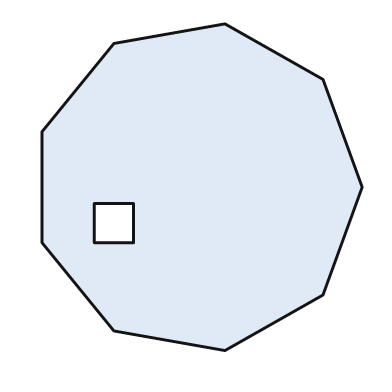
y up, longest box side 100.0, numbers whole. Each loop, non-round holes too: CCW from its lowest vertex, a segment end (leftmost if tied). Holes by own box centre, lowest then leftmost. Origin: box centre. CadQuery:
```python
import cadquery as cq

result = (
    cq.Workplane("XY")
    .moveTo(7.0, -50.0)
    .lineTo(37.0, -33.0)
    .lineTo(49.0, 0.0)
    .lineTo(37.0, 33.0)
    .lineTo(7.0, 50.0)
    .lineTo(-27.0, 44.0)
    .lineTo(-49.0, 17.0)
    .lineTo(-49.0, -17.0)
    .lineTo(-27.0, -44.0)
    .close()
    .moveTo(-33.0, -17.0)
    .lineTo(-21.0, -17.0)
    .lineTo(-21.0, -5.0)
    .lineTo(-33.0, -5.0)
    .close()
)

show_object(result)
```